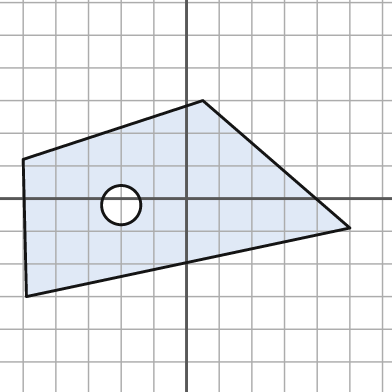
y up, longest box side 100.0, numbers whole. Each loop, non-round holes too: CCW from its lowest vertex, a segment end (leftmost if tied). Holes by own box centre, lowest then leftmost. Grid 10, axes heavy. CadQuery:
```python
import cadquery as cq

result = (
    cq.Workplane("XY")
    .moveTo(-49.0, -30.0)
    .lineTo(50.0, -9.0)
    .lineTo(5.0, 30.0)
    .lineTo(-50.0, 12.0)
    .close()
    .moveTo(-20.0, -2.0)
    .circle(6.0)
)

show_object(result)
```